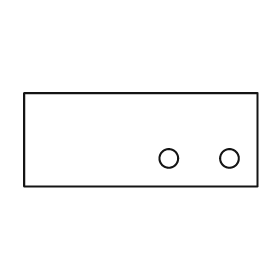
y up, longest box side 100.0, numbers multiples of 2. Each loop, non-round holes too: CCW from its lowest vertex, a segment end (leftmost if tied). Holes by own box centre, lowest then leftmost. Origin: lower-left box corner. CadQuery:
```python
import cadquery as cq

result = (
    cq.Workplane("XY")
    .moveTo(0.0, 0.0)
    .lineTo(100.0, 0.0)
    .lineTo(100.0, 40.0)
    .lineTo(0.0, 40.0)
    .close()
    .moveTo(62.0, 12.0)
    .circle(4.0)
    .moveTo(88.0, 12.0)
    .circle(4.0)
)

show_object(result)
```